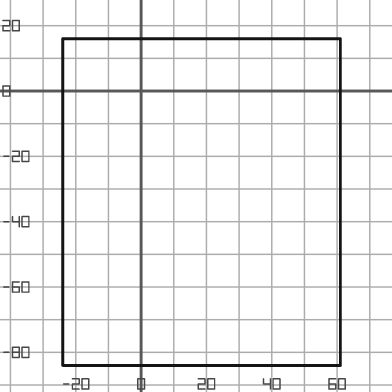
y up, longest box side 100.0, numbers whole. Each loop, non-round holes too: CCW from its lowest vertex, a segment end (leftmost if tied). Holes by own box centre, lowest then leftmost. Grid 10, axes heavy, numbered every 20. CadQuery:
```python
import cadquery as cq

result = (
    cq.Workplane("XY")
    .moveTo(-24.0, -84.0)
    .lineTo(61.0, -84.0)
    .lineTo(61.0, 16.0)
    .lineTo(-24.0, 16.0)
    .close()
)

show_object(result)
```